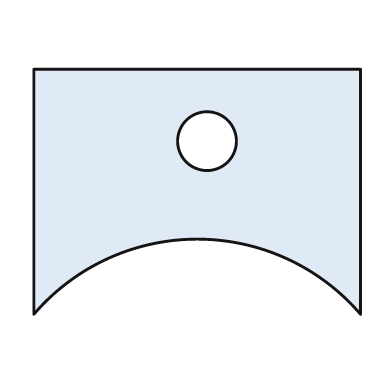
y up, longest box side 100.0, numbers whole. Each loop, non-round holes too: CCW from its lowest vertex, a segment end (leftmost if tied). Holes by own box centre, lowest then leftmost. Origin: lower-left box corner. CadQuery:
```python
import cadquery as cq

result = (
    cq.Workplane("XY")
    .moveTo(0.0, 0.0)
    .threePointArc((50.0, 23.0), (100.0, 0.0))
    .lineTo(100.0, 75.0)
    .lineTo(0.0, 75.0)
    .close()
    .moveTo(53.0, 53.0)
    .circle(9.0)
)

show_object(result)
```